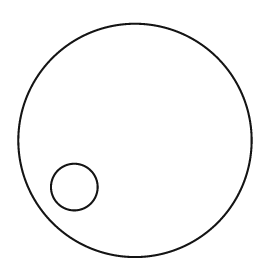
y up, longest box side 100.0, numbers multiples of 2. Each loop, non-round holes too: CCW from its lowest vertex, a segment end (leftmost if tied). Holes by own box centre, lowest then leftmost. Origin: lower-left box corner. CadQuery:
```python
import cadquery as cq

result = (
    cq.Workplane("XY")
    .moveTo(50.0, 50.0)
    .circle(50.0)
    .moveTo(24.0, 30.0)
    .circle(10.0)
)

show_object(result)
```